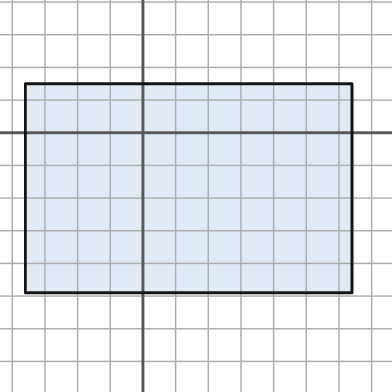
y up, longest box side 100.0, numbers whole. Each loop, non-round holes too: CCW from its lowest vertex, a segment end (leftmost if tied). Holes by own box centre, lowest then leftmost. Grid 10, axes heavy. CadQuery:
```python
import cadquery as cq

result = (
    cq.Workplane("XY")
    .moveTo(-36.0, -49.0)
    .lineTo(64.0, -49.0)
    .lineTo(64.0, 15.0)
    .lineTo(-36.0, 15.0)
    .close()
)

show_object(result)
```